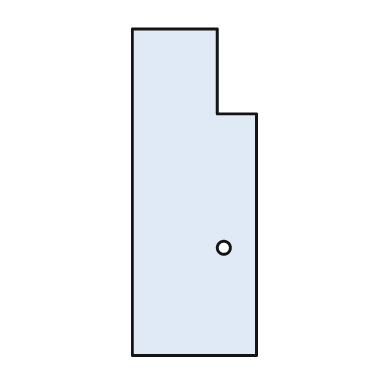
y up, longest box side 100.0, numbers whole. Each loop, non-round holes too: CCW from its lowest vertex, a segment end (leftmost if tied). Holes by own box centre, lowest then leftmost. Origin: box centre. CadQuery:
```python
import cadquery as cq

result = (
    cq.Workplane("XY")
    .moveTo(-19.0, -50.0)
    .lineTo(19.0, -50.0)
    .lineTo(19.0, 24.0)
    .lineTo(7.0, 24.0)
    .lineTo(7.0, 50.0)
    .lineTo(-19.0, 50.0)
    .close()
    .moveTo(9.0, -17.0)
    .circle(2.0)
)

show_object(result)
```